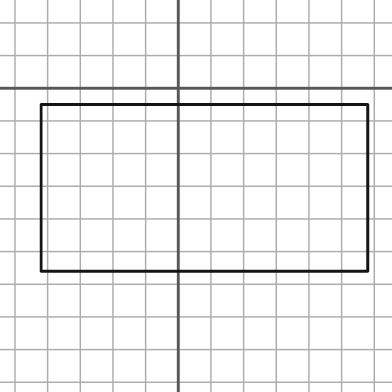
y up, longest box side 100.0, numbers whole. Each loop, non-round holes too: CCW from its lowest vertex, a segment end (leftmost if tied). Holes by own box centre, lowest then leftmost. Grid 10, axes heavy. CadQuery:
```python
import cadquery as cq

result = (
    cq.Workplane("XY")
    .moveTo(-42.0, -56.0)
    .lineTo(58.0, -56.0)
    .lineTo(58.0, -5.0)
    .lineTo(-42.0, -5.0)
    .close()
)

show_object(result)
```